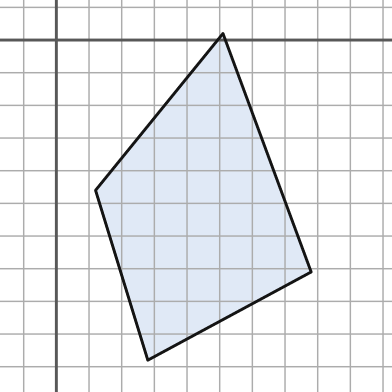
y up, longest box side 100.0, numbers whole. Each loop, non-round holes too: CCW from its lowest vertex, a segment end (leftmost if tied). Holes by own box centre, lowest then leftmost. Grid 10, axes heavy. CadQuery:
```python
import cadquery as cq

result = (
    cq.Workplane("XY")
    .moveTo(28.0, -98.0)
    .lineTo(78.0, -71.0)
    .lineTo(51.0, 2.0)
    .lineTo(12.0, -46.0)
    .close()
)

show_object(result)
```